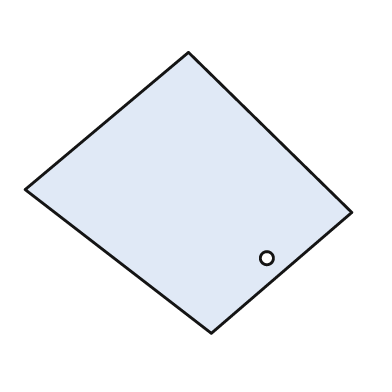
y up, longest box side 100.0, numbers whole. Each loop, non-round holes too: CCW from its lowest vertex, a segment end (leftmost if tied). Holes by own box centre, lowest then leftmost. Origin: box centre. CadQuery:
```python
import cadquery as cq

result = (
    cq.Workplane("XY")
    .moveTo(7.0, -43.0)
    .lineTo(50.0, -6.0)
    .lineTo(0.0, 43.0)
    .lineTo(-50.0, 1.0)
    .close()
    .moveTo(24.0, -20.0)
    .circle(2.0)
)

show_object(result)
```